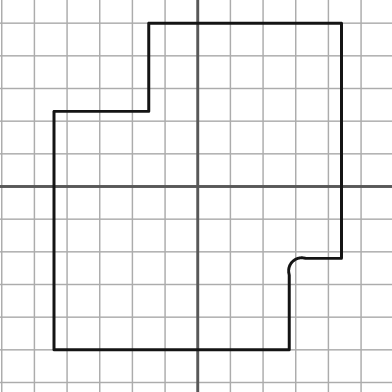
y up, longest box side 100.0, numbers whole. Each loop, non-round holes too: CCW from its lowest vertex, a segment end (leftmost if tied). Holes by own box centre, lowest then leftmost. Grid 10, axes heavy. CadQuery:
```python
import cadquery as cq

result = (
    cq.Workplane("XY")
    .moveTo(-44.0, -50.0)
    .lineTo(28.0, -50.0)
    .lineTo(28.0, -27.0)
    .threePointArc((29.0, -23.0), (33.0, -22.0))
    .lineTo(44.0, -22.0)
    .lineTo(44.0, 50.0)
    .lineTo(-15.0, 50.0)
    .lineTo(-15.0, 23.0)
    .lineTo(-44.0, 23.0)
    .close()
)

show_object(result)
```